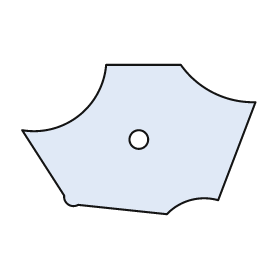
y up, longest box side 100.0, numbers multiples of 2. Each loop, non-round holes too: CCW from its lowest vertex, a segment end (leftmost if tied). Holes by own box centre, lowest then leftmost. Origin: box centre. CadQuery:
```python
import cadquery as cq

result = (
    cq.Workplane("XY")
    .moveTo(12.0, -32.0)
    .threePointArc((22.0, -26.0), (34.0, -26.0))
    .lineTo(50.0, 16.0)
    .threePointArc((32.0, 20.0), (18.0, 32.0))
    .lineTo(-14.0, 32.0)
    .threePointArc((-26.0, 10.0), (-50.0, 4.0))
    .lineTo(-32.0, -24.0)
    .threePointArc((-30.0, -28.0), (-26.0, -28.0))
    .close()
    .moveTo(0.0, 0.0)
    .circle(4.0)
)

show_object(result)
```